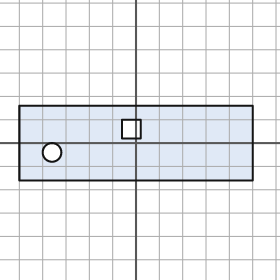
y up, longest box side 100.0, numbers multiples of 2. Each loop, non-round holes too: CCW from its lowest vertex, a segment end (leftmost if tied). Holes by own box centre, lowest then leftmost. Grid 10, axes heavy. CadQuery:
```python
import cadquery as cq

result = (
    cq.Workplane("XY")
    .moveTo(-50.0, -16.0)
    .lineTo(50.0, -16.0)
    .lineTo(50.0, 16.0)
    .lineTo(-50.0, 16.0)
    .close()
    .moveTo(-36.0, -4.0)
    .circle(4.0)
    .moveTo(-6.0, 2.0)
    .lineTo(2.0, 2.0)
    .lineTo(2.0, 10.0)
    .lineTo(-6.0, 10.0)
    .close()
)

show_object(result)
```